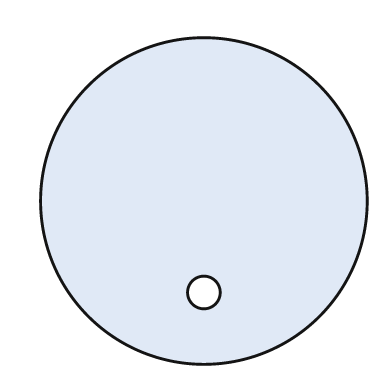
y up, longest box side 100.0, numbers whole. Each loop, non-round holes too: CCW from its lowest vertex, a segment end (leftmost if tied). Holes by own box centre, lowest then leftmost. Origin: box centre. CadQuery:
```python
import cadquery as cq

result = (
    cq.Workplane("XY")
    .moveTo(0.0, 0.0)
    .circle(50.0)
    .moveTo(0.0, -28.0)
    .circle(5.0)
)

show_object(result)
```